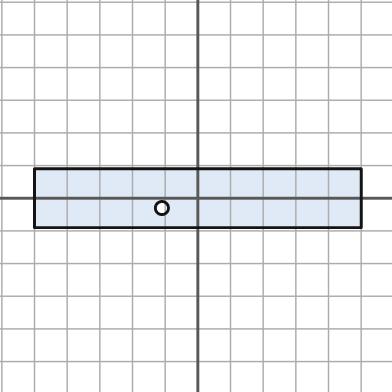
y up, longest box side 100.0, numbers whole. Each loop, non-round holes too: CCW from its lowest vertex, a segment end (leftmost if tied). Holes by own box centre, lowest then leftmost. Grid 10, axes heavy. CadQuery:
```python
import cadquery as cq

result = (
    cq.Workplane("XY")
    .moveTo(-50.0, -9.0)
    .lineTo(50.0, -9.0)
    .lineTo(50.0, 9.0)
    .lineTo(-50.0, 9.0)
    .close()
    .moveTo(-11.0, -3.0)
    .circle(2.0)
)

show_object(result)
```